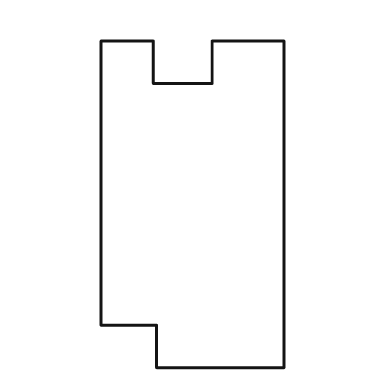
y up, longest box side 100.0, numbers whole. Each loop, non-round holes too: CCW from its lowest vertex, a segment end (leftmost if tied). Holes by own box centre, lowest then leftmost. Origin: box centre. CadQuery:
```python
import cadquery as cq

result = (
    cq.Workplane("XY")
    .moveTo(-11.0, -50.0)
    .lineTo(28.0, -50.0)
    .lineTo(28.0, 50.0)
    .lineTo(6.0, 50.0)
    .lineTo(6.0, 37.0)
    .lineTo(-12.0, 37.0)
    .lineTo(-12.0, 50.0)
    .lineTo(-28.0, 50.0)
    .lineTo(-28.0, -37.0)
    .lineTo(-11.0, -37.0)
    .close()
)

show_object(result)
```